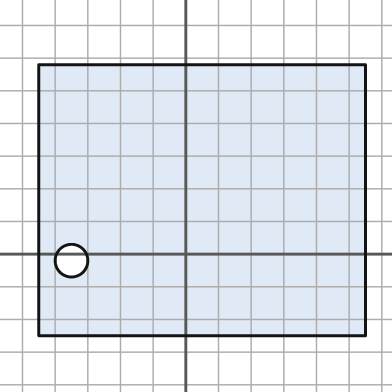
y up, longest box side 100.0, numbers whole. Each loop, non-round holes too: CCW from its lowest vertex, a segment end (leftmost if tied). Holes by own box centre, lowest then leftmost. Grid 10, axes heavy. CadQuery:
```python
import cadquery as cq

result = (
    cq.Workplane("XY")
    .moveTo(-45.0, -25.0)
    .lineTo(55.0, -25.0)
    .lineTo(55.0, 58.0)
    .lineTo(-45.0, 58.0)
    .close()
    .moveTo(-35.0, -2.0)
    .circle(5.0)
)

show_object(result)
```